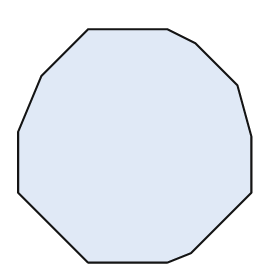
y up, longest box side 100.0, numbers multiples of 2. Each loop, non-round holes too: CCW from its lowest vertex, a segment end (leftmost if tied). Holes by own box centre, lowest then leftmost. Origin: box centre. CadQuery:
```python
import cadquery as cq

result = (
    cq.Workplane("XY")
    .moveTo(-20.0, -50.0)
    .lineTo(14.0, -50.0)
    .lineTo(24.0, -46.0)
    .lineTo(50.0, -20.0)
    .lineTo(50.0, 4.0)
    .lineTo(44.0, 26.0)
    .lineTo(26.0, 44.0)
    .lineTo(14.0, 50.0)
    .lineTo(-20.0, 50.0)
    .lineTo(-40.0, 30.0)
    .lineTo(-50.0, 6.0)
    .lineTo(-50.0, -20.0)
    .close()
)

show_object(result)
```